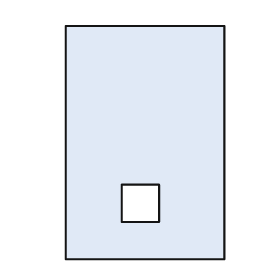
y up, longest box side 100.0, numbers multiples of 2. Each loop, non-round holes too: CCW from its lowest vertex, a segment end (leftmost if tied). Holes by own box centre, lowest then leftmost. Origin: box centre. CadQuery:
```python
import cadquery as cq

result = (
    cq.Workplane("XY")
    .moveTo(-34.0, -50.0)
    .lineTo(34.0, -50.0)
    .lineTo(34.0, 50.0)
    .lineTo(-34.0, 50.0)
    .close()
    .moveTo(-10.0, -34.0)
    .lineTo(6.0, -34.0)
    .lineTo(6.0, -18.0)
    .lineTo(-10.0, -18.0)
    .close()
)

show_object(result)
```